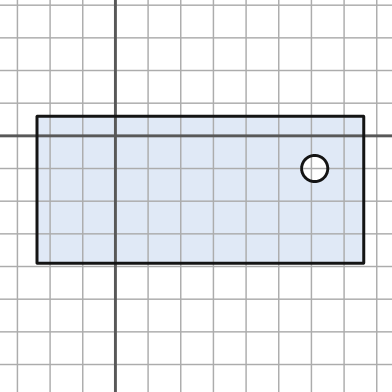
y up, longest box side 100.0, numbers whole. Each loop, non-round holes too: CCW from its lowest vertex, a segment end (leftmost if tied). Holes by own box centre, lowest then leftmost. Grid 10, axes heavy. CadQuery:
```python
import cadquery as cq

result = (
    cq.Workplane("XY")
    .moveTo(-24.0, -39.0)
    .lineTo(76.0, -39.0)
    .lineTo(76.0, 6.0)
    .lineTo(-24.0, 6.0)
    .close()
    .moveTo(61.0, -10.0)
    .circle(4.0)
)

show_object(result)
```